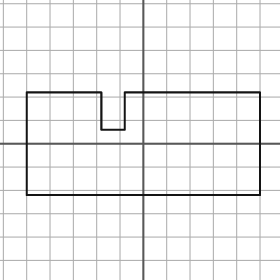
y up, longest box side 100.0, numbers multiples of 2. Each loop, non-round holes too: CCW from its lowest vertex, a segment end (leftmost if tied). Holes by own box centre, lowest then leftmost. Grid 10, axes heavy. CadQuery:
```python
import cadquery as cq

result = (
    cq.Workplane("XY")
    .moveTo(-50.0, -22.0)
    .lineTo(50.0, -22.0)
    .lineTo(50.0, 22.0)
    .lineTo(-8.0, 22.0)
    .lineTo(-8.0, 6.0)
    .lineTo(-18.0, 6.0)
    .lineTo(-18.0, 22.0)
    .lineTo(-50.0, 22.0)
    .close()
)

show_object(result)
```